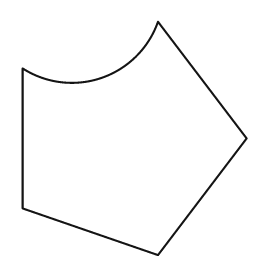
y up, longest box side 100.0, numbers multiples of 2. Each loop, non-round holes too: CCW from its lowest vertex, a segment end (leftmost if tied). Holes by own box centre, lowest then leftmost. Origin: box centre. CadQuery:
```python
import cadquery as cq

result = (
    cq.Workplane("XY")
    .moveTo(10.0, -50.0)
    .lineTo(48.0, 0.0)
    .lineTo(10.0, 50.0)
    .threePointArc((-14.0, 26.0), (-48.0, 30.0))
    .lineTo(-48.0, -30.0)
    .close()
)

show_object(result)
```